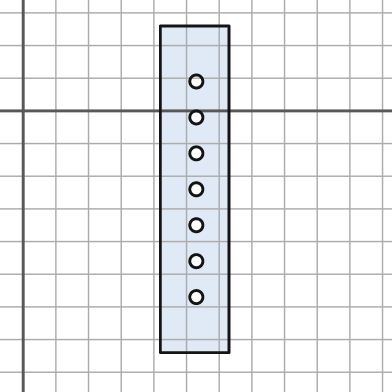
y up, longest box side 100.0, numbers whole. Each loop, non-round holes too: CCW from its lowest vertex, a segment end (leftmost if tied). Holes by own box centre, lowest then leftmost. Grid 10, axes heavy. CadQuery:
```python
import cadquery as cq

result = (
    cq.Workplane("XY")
    .moveTo(42.0, -74.0)
    .lineTo(63.0, -74.0)
    .lineTo(63.0, 26.0)
    .lineTo(42.0, 26.0)
    .close()
    .moveTo(53.0, -57.0)
    .circle(2.0)
    .moveTo(53.0, -46.0)
    .circle(2.0)
    .moveTo(53.0, -35.0)
    .circle(2.0)
    .moveTo(53.0, -24.0)
    .circle(2.0)
    .moveTo(53.0, -13.0)
    .circle(2.0)
    .moveTo(53.0, -2.0)
    .circle(2.0)
    .moveTo(53.0, 9.0)
    .circle(2.0)
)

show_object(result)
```